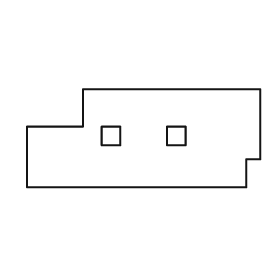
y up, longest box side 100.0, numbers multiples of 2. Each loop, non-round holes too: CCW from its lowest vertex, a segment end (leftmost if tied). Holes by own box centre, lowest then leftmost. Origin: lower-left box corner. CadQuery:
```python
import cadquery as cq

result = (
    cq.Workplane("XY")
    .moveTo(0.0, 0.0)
    .lineTo(94.0, 0.0)
    .lineTo(94.0, 12.0)
    .lineTo(100.0, 12.0)
    .lineTo(100.0, 42.0)
    .lineTo(24.0, 42.0)
    .lineTo(24.0, 26.0)
    .lineTo(0.0, 26.0)
    .close()
    .moveTo(32.0, 18.0)
    .lineTo(40.0, 18.0)
    .lineTo(40.0, 26.0)
    .lineTo(32.0, 26.0)
    .close()
    .moveTo(60.0, 18.0)
    .lineTo(68.0, 18.0)
    .lineTo(68.0, 26.0)
    .lineTo(60.0, 26.0)
    .close()
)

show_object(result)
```